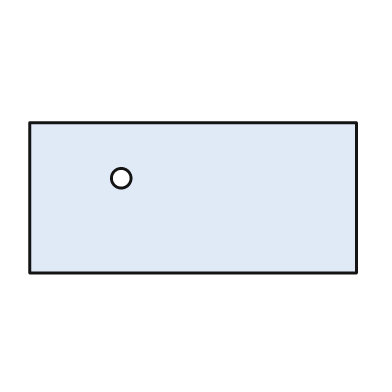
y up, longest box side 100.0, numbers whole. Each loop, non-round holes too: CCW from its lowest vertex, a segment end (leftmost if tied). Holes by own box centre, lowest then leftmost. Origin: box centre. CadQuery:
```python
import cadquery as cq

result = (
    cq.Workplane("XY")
    .moveTo(-50.0, -23.0)
    .lineTo(50.0, -23.0)
    .lineTo(50.0, 23.0)
    .lineTo(-50.0, 23.0)
    .close()
    .moveTo(-22.0, 6.0)
    .circle(3.0)
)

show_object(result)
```